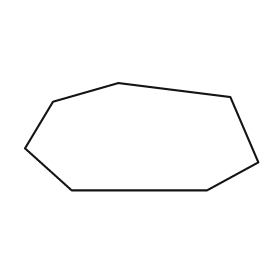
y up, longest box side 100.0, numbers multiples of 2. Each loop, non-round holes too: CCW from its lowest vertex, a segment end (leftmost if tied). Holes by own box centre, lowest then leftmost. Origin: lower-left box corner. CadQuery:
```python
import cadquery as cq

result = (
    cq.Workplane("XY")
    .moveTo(20.0, 0.0)
    .lineTo(78.0, 0.0)
    .lineTo(100.0, 12.0)
    .lineTo(88.0, 40.0)
    .lineTo(40.0, 46.0)
    .lineTo(12.0, 38.0)
    .lineTo(0.0, 18.0)
    .close()
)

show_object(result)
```